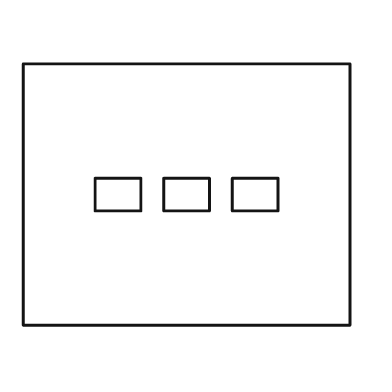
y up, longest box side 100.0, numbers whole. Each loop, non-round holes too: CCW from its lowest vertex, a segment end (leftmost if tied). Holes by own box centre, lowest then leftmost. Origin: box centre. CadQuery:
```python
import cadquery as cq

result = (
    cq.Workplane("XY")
    .moveTo(-50.0, -40.0)
    .lineTo(50.0, -40.0)
    .lineTo(50.0, 40.0)
    .lineTo(-50.0, 40.0)
    .close()
    .moveTo(-28.0, -5.0)
    .lineTo(-14.0, -5.0)
    .lineTo(-14.0, 5.0)
    .lineTo(-28.0, 5.0)
    .close()
    .moveTo(-7.0, -5.0)
    .lineTo(7.0, -5.0)
    .lineTo(7.0, 5.0)
    .lineTo(-7.0, 5.0)
    .close()
    .moveTo(14.0, -5.0)
    .lineTo(28.0, -5.0)
    .lineTo(28.0, 5.0)
    .lineTo(14.0, 5.0)
    .close()
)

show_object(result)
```